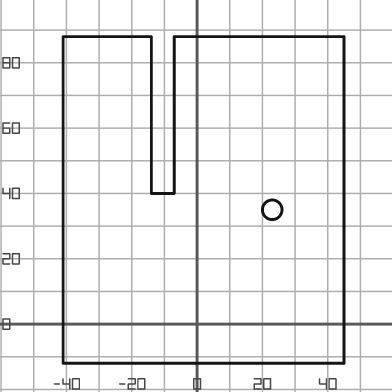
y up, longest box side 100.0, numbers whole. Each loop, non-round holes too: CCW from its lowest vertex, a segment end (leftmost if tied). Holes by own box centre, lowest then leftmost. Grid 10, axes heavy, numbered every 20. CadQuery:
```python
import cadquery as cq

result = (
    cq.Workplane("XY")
    .moveTo(-41.0, -12.0)
    .lineTo(45.0, -12.0)
    .lineTo(45.0, 88.0)
    .lineTo(-7.0, 88.0)
    .lineTo(-7.0, 40.0)
    .lineTo(-14.0, 40.0)
    .lineTo(-14.0, 88.0)
    .lineTo(-41.0, 88.0)
    .close()
    .moveTo(23.0, 35.0)
    .circle(3.0)
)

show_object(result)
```